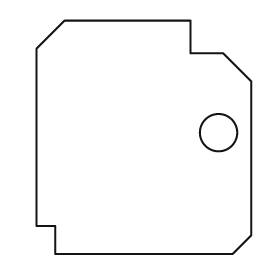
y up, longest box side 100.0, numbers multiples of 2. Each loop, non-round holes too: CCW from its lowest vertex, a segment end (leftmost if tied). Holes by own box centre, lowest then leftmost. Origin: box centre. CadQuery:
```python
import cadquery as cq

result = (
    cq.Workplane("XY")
    .moveTo(-38.0, -50.0)
    .lineTo(38.0, -50.0)
    .lineTo(46.0, -42.0)
    .lineTo(46.0, 24.0)
    .lineTo(34.0, 36.0)
    .lineTo(20.0, 36.0)
    .lineTo(20.0, 50.0)
    .lineTo(-34.0, 50.0)
    .lineTo(-46.0, 38.0)
    .lineTo(-46.0, -38.0)
    .lineTo(-38.0, -38.0)
    .close()
    .moveTo(32.0, 2.0)
    .circle(8.0)
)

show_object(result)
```